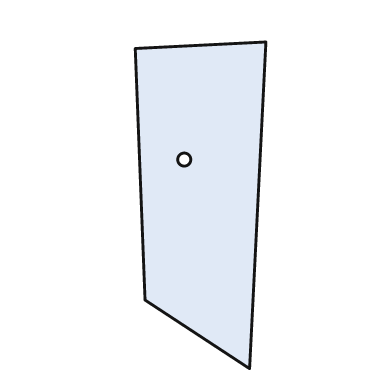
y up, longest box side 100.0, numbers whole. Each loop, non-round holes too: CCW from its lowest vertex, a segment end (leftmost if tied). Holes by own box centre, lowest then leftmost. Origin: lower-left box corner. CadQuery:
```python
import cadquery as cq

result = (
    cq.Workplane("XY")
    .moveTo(35.0, 0.0)
    .lineTo(40.0, 100.0)
    .lineTo(0.0, 98.0)
    .lineTo(3.0, 21.0)
    .close()
    .moveTo(15.0, 64.0)
    .circle(2.0)
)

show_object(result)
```